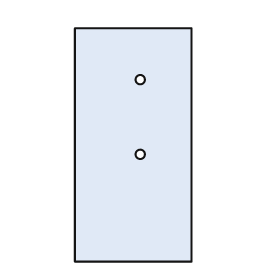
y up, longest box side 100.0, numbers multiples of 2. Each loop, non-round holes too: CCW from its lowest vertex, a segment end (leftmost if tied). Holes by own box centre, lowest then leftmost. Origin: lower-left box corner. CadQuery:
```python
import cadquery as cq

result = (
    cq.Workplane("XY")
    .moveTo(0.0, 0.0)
    .lineTo(50.0, 0.0)
    .lineTo(50.0, 100.0)
    .lineTo(0.0, 100.0)
    .close()
    .moveTo(28.0, 46.0)
    .circle(2.0)
    .moveTo(28.0, 78.0)
    .circle(2.0)
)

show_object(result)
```